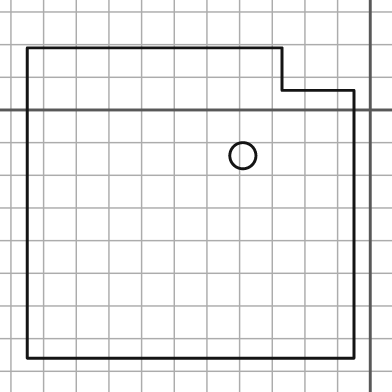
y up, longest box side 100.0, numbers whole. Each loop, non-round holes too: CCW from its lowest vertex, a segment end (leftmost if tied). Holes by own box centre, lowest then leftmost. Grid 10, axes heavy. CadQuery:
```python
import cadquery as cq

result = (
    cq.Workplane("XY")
    .moveTo(-105.0, -76.0)
    .lineTo(-5.0, -76.0)
    .lineTo(-5.0, 6.0)
    .lineTo(-27.0, 6.0)
    .lineTo(-27.0, 19.0)
    .lineTo(-105.0, 19.0)
    .close()
    .moveTo(-39.0, -14.0)
    .circle(4.0)
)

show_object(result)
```